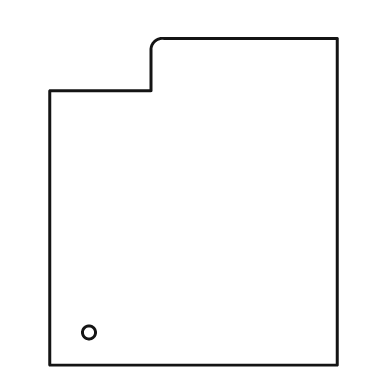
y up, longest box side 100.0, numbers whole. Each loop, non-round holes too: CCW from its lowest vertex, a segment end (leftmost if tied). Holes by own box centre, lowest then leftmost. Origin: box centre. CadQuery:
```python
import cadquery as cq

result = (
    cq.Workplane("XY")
    .moveTo(-44.0, -50.0)
    .lineTo(44.0, -50.0)
    .lineTo(44.0, 50.0)
    .lineTo(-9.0, 50.0)
    .threePointArc((-12.0, 49.0), (-13.0, 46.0))
    .lineTo(-13.0, 34.0)
    .lineTo(-44.0, 34.0)
    .close()
    .moveTo(-32.0, -40.0)
    .circle(2.0)
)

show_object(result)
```